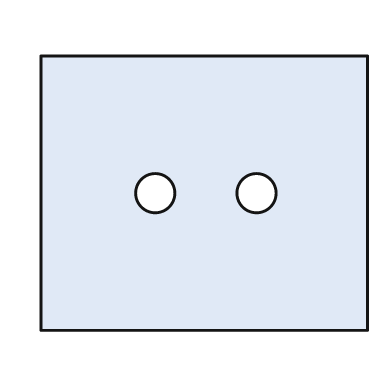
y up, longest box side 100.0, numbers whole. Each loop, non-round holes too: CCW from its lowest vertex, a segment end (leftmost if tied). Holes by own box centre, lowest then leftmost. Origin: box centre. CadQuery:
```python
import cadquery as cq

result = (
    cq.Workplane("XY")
    .moveTo(-50.0, -42.0)
    .lineTo(50.0, -42.0)
    .lineTo(50.0, 42.0)
    .lineTo(-50.0, 42.0)
    .close()
    .moveTo(-15.0, 0.0)
    .circle(6.0)
    .moveTo(16.0, 0.0)
    .circle(6.0)
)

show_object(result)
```